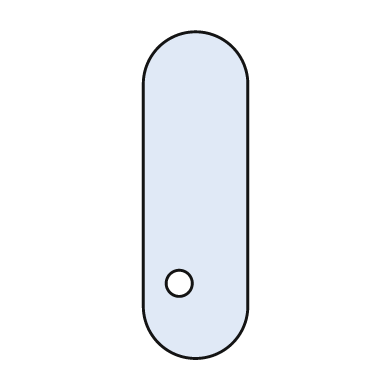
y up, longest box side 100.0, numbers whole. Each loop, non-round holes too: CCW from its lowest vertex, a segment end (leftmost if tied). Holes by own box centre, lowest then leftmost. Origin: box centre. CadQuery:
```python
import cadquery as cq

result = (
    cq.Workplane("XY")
    .moveTo(-16.0, -34.0)
    .threePointArc((0.0, -50.0), (16.0, -34.0))
    .lineTo(16.0, 34.0)
    .threePointArc((0.0, 50.0), (-16.0, 34.0))
    .close()
    .moveTo(-5.0, -27.0)
    .circle(4.0)
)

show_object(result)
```